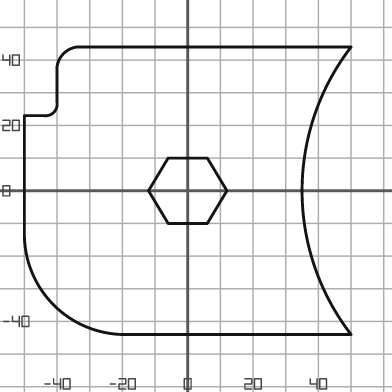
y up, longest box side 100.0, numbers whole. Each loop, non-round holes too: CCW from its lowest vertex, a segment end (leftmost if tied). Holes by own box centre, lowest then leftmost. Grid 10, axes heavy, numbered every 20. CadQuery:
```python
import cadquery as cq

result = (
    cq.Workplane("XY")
    .moveTo(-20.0, -44.0)
    .lineTo(50.0, -44.0)
    .threePointArc((35.0, 0.0), (50.0, 44.0))
    .lineTo(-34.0, 44.0)
    .threePointArc((-38.0, 42.0), (-40.0, 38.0))
    .lineTo(-40.0, 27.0)
    .threePointArc((-41.0, 24.0), (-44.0, 23.0))
    .lineTo(-50.0, 23.0)
    .lineTo(-50.0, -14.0)
    .threePointArc((-41.0, -35.0), (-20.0, -44.0))
    .close()
    .moveTo(-6.0, -10.0)
    .lineTo(6.0, -10.0)
    .lineTo(12.0, 0.0)
    .lineTo(6.0, 10.0)
    .lineTo(-6.0, 10.0)
    .lineTo(-12.0, 0.0)
    .close()
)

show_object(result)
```